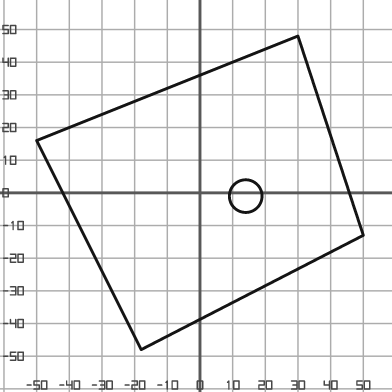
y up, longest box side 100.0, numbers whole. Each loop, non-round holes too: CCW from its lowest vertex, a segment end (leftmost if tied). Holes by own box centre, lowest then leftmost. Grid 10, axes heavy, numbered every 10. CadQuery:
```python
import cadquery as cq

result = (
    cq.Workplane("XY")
    .moveTo(-18.0, -48.0)
    .lineTo(50.0, -13.0)
    .lineTo(30.0, 48.0)
    .lineTo(-50.0, 16.0)
    .close()
    .moveTo(14.0, -1.0)
    .circle(5.0)
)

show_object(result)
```